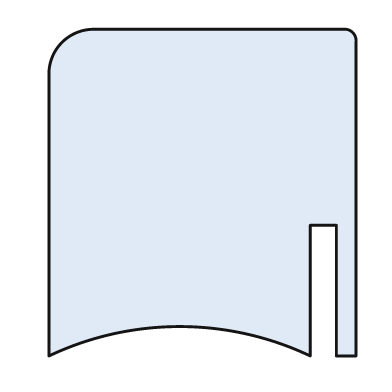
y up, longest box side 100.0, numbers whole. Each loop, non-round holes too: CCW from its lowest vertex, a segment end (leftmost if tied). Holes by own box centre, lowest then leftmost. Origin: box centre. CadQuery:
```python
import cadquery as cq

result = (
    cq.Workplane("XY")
    .moveTo(-47.0, -50.0)
    .threePointArc((-7.0, -41.0), (33.0, -50.0))
    .lineTo(33.0, -10.0)
    .lineTo(41.0, -10.0)
    .lineTo(41.0, -50.0)
    .lineTo(47.0, -50.0)
    .lineTo(47.0, 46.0)
    .threePointArc((46.0, 49.0), (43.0, 50.0))
    .lineTo(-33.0, 50.0)
    .threePointArc((-43.0, 46.0), (-47.0, 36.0))
    .close()
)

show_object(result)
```